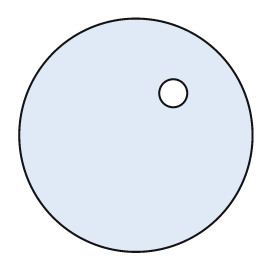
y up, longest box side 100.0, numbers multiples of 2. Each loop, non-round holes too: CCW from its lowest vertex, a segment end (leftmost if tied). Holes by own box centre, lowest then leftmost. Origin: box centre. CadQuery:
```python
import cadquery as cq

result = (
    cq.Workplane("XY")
    .moveTo(0.0, 0.0)
    .circle(50.0)
    .moveTo(16.0, 18.0)
    .circle(6.0)
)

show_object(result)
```